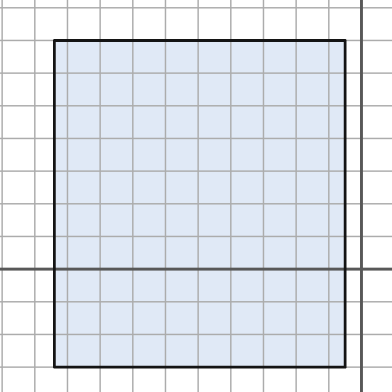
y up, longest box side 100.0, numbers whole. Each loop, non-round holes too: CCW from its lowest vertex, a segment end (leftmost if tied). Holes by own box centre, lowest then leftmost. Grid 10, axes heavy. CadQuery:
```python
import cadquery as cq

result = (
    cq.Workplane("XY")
    .moveTo(-94.0, -30.0)
    .lineTo(-5.0, -30.0)
    .lineTo(-5.0, 70.0)
    .lineTo(-94.0, 70.0)
    .close()
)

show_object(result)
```